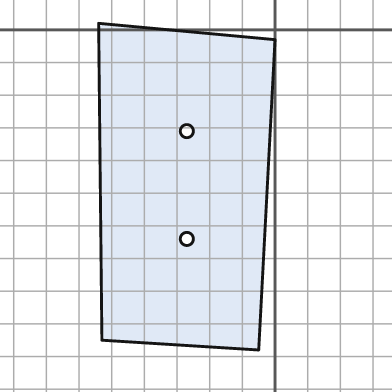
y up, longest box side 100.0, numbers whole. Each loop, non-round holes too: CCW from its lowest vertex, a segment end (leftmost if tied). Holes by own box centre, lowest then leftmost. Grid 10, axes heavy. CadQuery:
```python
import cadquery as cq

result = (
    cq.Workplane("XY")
    .moveTo(-5.0, -98.0)
    .lineTo(0.0, -3.0)
    .lineTo(-54.0, 2.0)
    .lineTo(-53.0, -95.0)
    .close()
    .moveTo(-27.0, -64.0)
    .circle(2.0)
    .moveTo(-27.0, -31.0)
    .circle(2.0)
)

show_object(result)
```